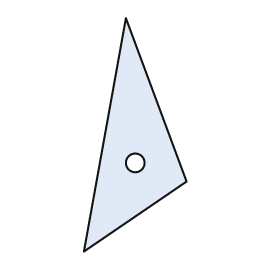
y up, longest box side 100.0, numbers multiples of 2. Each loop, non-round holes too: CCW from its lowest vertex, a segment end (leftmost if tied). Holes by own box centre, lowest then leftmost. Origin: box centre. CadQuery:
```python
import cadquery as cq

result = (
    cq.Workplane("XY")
    .moveTo(-22.0, -50.0)
    .lineTo(22.0, -20.0)
    .lineTo(-4.0, 50.0)
    .close()
    .moveTo(0.0, -12.0)
    .circle(4.0)
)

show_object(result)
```